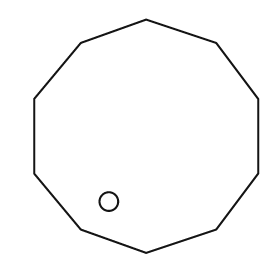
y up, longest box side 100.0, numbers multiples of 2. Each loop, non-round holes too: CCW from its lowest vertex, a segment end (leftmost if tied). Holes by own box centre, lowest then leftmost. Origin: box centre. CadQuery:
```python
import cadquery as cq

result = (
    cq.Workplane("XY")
    .moveTo(0.0, -50.0)
    .lineTo(30.0, -40.0)
    .lineTo(48.0, -16.0)
    .lineTo(48.0, 16.0)
    .lineTo(30.0, 40.0)
    .lineTo(0.0, 50.0)
    .lineTo(-28.0, 40.0)
    .lineTo(-48.0, 16.0)
    .lineTo(-48.0, -16.0)
    .lineTo(-28.0, -40.0)
    .close()
    .moveTo(-16.0, -28.0)
    .circle(4.0)
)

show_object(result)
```